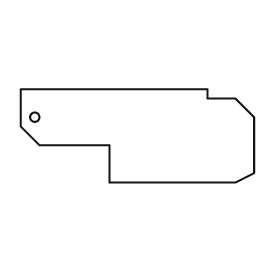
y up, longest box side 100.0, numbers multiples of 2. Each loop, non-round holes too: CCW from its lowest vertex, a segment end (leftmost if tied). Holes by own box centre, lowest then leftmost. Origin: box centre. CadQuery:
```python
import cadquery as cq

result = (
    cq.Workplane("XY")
    .moveTo(-12.0, -20.0)
    .lineTo(42.0, -20.0)
    .lineTo(50.0, -16.0)
    .lineTo(50.0, 8.0)
    .lineTo(42.0, 16.0)
    .lineTo(30.0, 16.0)
    .lineTo(30.0, 20.0)
    .lineTo(-50.0, 20.0)
    .lineTo(-50.0, 4.0)
    .lineTo(-42.0, -4.0)
    .lineTo(-12.0, -4.0)
    .close()
    .moveTo(-44.0, 8.0)
    .circle(2.0)
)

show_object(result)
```